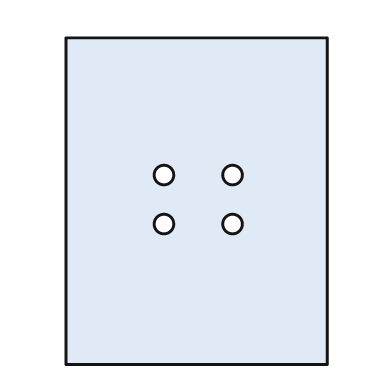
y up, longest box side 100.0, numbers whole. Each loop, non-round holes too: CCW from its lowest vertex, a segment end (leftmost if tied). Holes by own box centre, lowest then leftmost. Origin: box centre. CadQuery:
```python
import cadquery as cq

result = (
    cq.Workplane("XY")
    .moveTo(-40.0, -50.0)
    .lineTo(40.0, -50.0)
    .lineTo(40.0, 50.0)
    .lineTo(-40.0, 50.0)
    .close()
    .moveTo(-10.0, -7.0)
    .circle(3.0)
    .moveTo(11.0, -7.0)
    .circle(3.0)
    .moveTo(-10.0, 8.0)
    .circle(3.0)
    .moveTo(11.0, 8.0)
    .circle(3.0)
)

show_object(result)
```